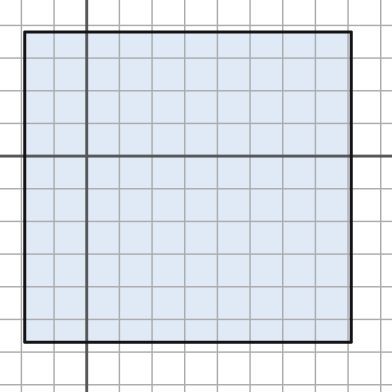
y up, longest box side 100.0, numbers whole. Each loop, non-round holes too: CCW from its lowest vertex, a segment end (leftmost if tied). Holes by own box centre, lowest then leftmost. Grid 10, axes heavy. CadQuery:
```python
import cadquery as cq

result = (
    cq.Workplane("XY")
    .moveTo(-19.0, -57.0)
    .lineTo(81.0, -57.0)
    .lineTo(81.0, 38.0)
    .lineTo(-19.0, 38.0)
    .close()
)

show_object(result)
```